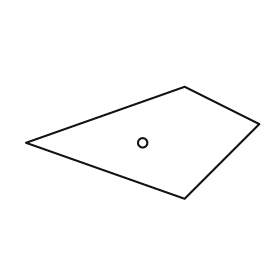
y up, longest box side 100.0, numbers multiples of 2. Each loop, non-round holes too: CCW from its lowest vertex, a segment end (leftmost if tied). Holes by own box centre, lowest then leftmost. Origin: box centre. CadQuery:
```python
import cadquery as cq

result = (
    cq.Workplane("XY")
    .moveTo(18.0, -24.0)
    .lineTo(50.0, 8.0)
    .lineTo(18.0, 24.0)
    .lineTo(-50.0, 0.0)
    .close()
    .moveTo(0.0, 0.0)
    .circle(2.0)
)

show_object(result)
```